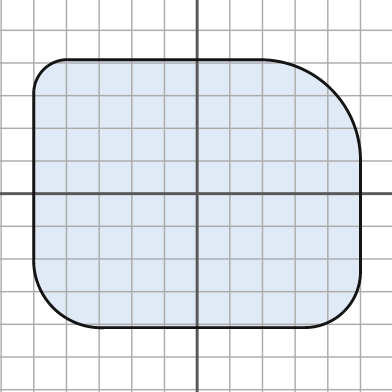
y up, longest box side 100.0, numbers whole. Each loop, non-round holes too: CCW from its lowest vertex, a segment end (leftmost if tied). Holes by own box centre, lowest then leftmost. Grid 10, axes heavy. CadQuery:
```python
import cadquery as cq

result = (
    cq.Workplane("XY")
    .moveTo(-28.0, -41.0)
    .lineTo(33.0, -41.0)
    .threePointArc((45.0, -36.0), (50.0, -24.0))
    .lineTo(50.0, 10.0)
    .threePointArc((41.0, 32.0), (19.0, 41.0))
    .lineTo(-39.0, 41.0)
    .threePointArc((-47.0, 38.0), (-50.0, 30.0))
    .lineTo(-50.0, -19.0)
    .threePointArc((-44.0, -35.0), (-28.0, -41.0))
    .close()
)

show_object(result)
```